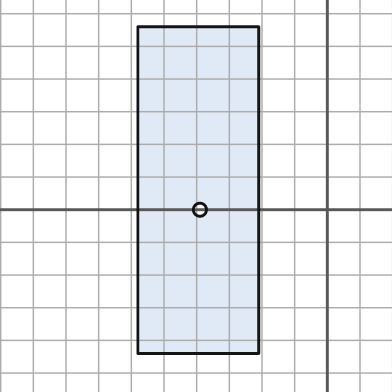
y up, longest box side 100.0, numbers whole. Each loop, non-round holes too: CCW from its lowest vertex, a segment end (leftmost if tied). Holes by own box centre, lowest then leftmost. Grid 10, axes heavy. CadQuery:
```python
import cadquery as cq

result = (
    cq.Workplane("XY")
    .moveTo(-58.0, -44.0)
    .lineTo(-21.0, -44.0)
    .lineTo(-21.0, 56.0)
    .lineTo(-58.0, 56.0)
    .close()
    .moveTo(-39.0, 0.0)
    .circle(2.0)
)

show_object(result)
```